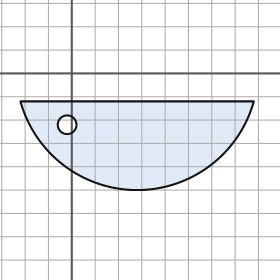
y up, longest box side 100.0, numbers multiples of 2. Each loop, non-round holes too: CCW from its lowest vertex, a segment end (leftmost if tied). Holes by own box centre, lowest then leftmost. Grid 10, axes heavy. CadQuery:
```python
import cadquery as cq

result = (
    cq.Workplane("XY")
    .moveTo(-22.0, -12.0)
    .threePointArc((28.0, -50.0), (78.0, -12.0))
    .close()
    .moveTo(-2.0, -22.0)
    .circle(4.0)
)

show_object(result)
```